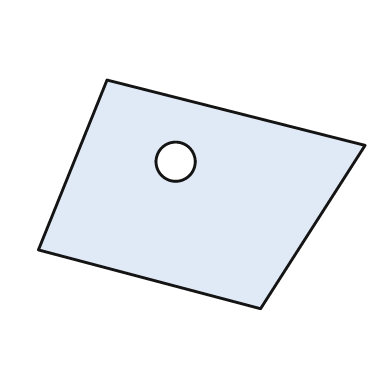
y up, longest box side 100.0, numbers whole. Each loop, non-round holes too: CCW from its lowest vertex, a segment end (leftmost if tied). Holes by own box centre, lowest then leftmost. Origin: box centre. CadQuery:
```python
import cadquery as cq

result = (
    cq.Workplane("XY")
    .moveTo(18.0, -35.0)
    .lineTo(50.0, 15.0)
    .lineTo(-29.0, 35.0)
    .lineTo(-50.0, -17.0)
    .close()
    .moveTo(-8.0, 10.0)
    .circle(6.0)
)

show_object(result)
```